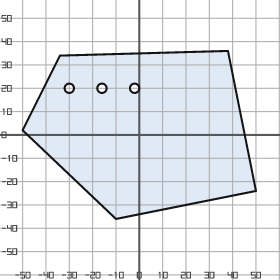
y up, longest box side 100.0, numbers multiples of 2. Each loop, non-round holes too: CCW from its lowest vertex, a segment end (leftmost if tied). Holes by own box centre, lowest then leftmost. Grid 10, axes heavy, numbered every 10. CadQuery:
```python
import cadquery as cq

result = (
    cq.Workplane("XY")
    .moveTo(-10.0, -36.0)
    .lineTo(50.0, -24.0)
    .lineTo(38.0, 36.0)
    .lineTo(-34.0, 34.0)
    .lineTo(-50.0, 2.0)
    .close()
    .moveTo(-30.0, 20.0)
    .circle(2.0)
    .moveTo(-16.0, 20.0)
    .circle(2.0)
    .moveTo(-2.0, 20.0)
    .circle(2.0)
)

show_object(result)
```